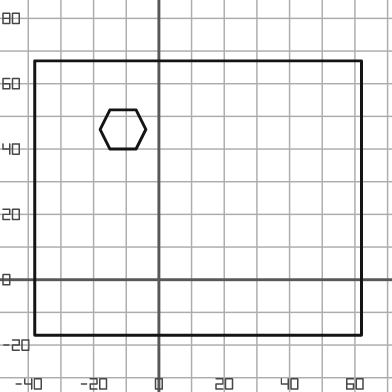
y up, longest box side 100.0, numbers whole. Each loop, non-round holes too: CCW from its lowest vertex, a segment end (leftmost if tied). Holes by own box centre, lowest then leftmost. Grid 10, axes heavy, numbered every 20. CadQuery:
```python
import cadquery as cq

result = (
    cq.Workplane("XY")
    .moveTo(-38.0, -17.0)
    .lineTo(62.0, -17.0)
    .lineTo(62.0, 67.0)
    .lineTo(-38.0, 67.0)
    .close()
    .moveTo(-15.0, 40.0)
    .lineTo(-7.0, 40.0)
    .lineTo(-4.0, 46.0)
    .lineTo(-7.0, 52.0)
    .lineTo(-15.0, 52.0)
    .lineTo(-18.0, 46.0)
    .close()
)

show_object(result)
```